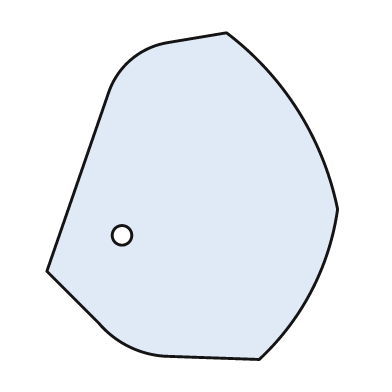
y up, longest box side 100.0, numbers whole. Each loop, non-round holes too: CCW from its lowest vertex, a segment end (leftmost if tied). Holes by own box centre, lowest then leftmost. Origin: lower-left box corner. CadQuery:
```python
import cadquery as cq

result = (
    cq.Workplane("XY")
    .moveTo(65.0, 0.0)
    .threePointArc((81.0, 21.0), (89.0, 46.0))
    .threePointArc((77.0, 76.0), (55.0, 100.0))
    .lineTo(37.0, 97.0)
    .threePointArc((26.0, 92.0), (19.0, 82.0))
    .lineTo(0.0, 27.0)
    .lineTo(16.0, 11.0)
    .threePointArc((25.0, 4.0), (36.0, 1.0))
    .close()
    .moveTo(23.0, 38.0)
    .circle(3.0)
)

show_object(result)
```